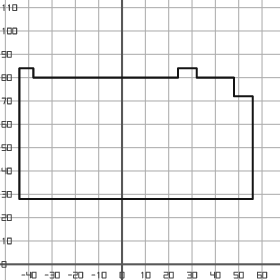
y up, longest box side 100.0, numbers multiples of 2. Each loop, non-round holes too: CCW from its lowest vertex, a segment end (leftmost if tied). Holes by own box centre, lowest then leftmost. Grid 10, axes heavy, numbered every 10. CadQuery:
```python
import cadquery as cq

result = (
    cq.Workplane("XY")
    .moveTo(-44.0, 28.0)
    .lineTo(56.0, 28.0)
    .lineTo(56.0, 72.0)
    .lineTo(48.0, 72.0)
    .lineTo(48.0, 80.0)
    .lineTo(32.0, 80.0)
    .lineTo(32.0, 84.0)
    .lineTo(24.0, 84.0)
    .lineTo(24.0, 80.0)
    .lineTo(-38.0, 80.0)
    .lineTo(-38.0, 84.0)
    .lineTo(-44.0, 84.0)
    .close()
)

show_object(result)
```